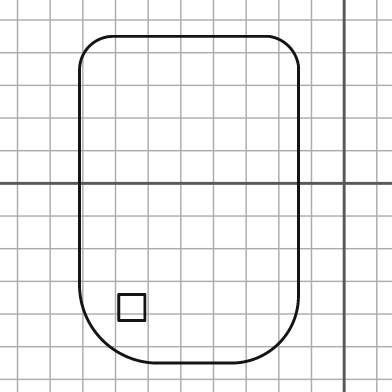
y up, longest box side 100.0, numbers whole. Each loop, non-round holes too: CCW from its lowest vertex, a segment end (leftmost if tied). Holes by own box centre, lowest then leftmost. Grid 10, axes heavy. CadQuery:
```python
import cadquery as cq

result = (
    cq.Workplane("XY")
    .moveTo(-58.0, -55.0)
    .lineTo(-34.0, -55.0)
    .threePointArc((-20.0, -49.0), (-14.0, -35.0))
    .lineTo(-14.0, 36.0)
    .threePointArc((-17.0, 42.0), (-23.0, 45.0))
    .lineTo(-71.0, 45.0)
    .threePointArc((-78.0, 42.0), (-81.0, 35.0))
    .lineTo(-81.0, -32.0)
    .threePointArc((-74.0, -48.0), (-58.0, -55.0))
    .close()
    .moveTo(-69.0, -42.0)
    .lineTo(-61.0, -42.0)
    .lineTo(-61.0, -34.0)
    .lineTo(-69.0, -34.0)
    .close()
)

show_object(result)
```